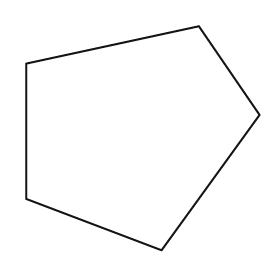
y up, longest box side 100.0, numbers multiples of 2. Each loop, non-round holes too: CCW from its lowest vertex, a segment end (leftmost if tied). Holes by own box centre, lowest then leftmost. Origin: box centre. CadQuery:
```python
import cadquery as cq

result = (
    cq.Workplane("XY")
    .moveTo(8.0, -48.0)
    .lineTo(50.0, 10.0)
    .lineTo(24.0, 48.0)
    .lineTo(-50.0, 32.0)
    .lineTo(-50.0, -26.0)
    .close()
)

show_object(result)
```